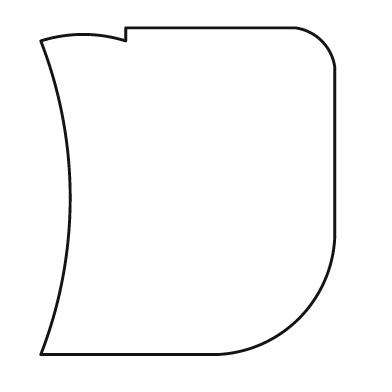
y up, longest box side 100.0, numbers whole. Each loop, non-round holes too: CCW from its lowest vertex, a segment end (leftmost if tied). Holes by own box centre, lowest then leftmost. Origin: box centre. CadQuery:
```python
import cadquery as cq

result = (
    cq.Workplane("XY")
    .moveTo(-45.0, -50.0)
    .lineTo(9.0, -50.0)
    .threePointArc((34.0, -39.0), (45.0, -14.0))
    .lineTo(45.0, 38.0)
    .threePointArc((41.0, 46.0), (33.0, 50.0))
    .lineTo(-19.0, 50.0)
    .lineTo(-19.0, 46.0)
    .threePointArc((-32.0, 48.0), (-45.0, 46.0))
    .threePointArc((-36.0, -2.0), (-45.0, -50.0))
    .close()
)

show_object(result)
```